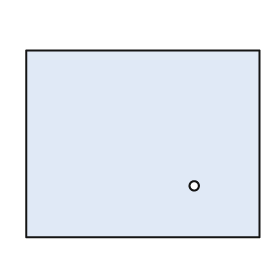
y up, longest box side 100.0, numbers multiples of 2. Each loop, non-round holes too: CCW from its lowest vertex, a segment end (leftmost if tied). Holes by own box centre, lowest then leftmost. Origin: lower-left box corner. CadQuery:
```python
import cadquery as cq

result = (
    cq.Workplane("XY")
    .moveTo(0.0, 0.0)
    .lineTo(100.0, 0.0)
    .lineTo(100.0, 80.0)
    .lineTo(0.0, 80.0)
    .close()
    .moveTo(72.0, 22.0)
    .circle(2.0)
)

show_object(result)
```